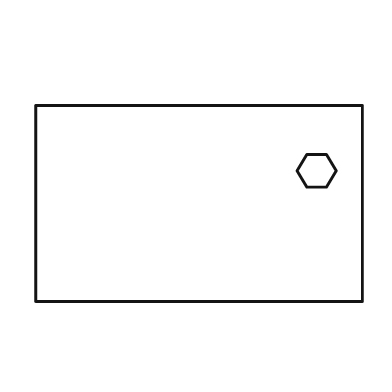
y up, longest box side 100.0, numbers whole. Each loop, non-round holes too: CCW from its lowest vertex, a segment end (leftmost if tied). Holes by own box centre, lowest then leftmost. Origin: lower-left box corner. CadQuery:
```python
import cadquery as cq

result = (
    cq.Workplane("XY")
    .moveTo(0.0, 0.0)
    .lineTo(100.0, 0.0)
    .lineTo(100.0, 60.0)
    .lineTo(0.0, 60.0)
    .close()
    .moveTo(83.0, 35.0)
    .lineTo(89.0, 35.0)
    .lineTo(92.0, 40.0)
    .lineTo(89.0, 45.0)
    .lineTo(83.0, 45.0)
    .lineTo(80.0, 40.0)
    .close()
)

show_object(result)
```